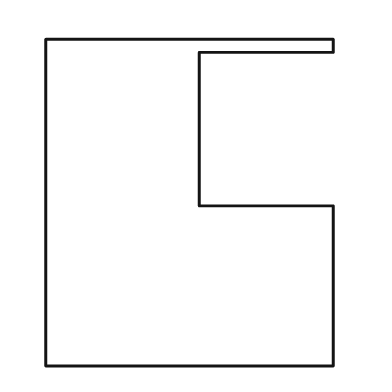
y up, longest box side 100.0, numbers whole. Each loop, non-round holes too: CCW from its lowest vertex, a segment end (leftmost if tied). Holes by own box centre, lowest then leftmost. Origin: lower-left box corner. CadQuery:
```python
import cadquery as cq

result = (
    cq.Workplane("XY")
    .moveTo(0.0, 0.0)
    .lineTo(88.0, 0.0)
    .lineTo(88.0, 49.0)
    .lineTo(47.0, 49.0)
    .lineTo(47.0, 96.0)
    .lineTo(88.0, 96.0)
    .lineTo(88.0, 100.0)
    .lineTo(0.0, 100.0)
    .close()
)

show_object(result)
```